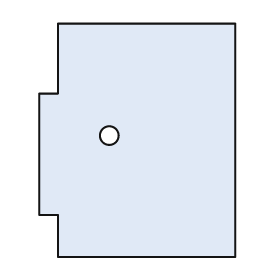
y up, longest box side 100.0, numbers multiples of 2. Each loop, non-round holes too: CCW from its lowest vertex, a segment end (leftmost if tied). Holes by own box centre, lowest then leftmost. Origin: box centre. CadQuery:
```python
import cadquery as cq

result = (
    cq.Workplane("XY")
    .moveTo(-34.0, -50.0)
    .lineTo(42.0, -50.0)
    .lineTo(42.0, 50.0)
    .lineTo(-34.0, 50.0)
    .lineTo(-34.0, 20.0)
    .lineTo(-42.0, 20.0)
    .lineTo(-42.0, -32.0)
    .lineTo(-34.0, -32.0)
    .close()
    .moveTo(-12.0, 2.0)
    .circle(4.0)
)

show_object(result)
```